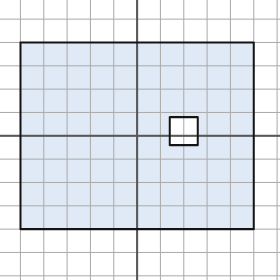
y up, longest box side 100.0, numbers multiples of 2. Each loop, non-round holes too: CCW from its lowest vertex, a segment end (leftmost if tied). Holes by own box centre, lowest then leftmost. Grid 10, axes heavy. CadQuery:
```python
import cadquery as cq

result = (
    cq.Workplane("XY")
    .moveTo(-50.0, -40.0)
    .lineTo(50.0, -40.0)
    .lineTo(50.0, 40.0)
    .lineTo(-50.0, 40.0)
    .close()
    .moveTo(14.0, -4.0)
    .lineTo(26.0, -4.0)
    .lineTo(26.0, 8.0)
    .lineTo(14.0, 8.0)
    .close()
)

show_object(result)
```